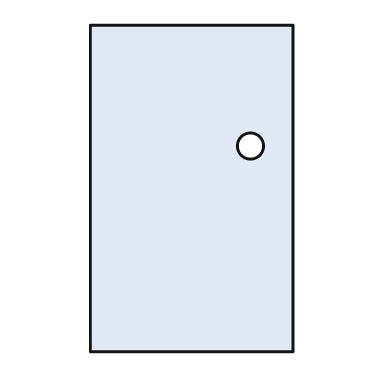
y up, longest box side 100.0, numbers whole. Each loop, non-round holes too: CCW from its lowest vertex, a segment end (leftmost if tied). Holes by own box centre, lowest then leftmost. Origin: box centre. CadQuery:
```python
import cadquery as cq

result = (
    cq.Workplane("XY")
    .moveTo(-31.0, -50.0)
    .lineTo(31.0, -50.0)
    .lineTo(31.0, 50.0)
    .lineTo(-31.0, 50.0)
    .close()
    .moveTo(18.0, 13.0)
    .circle(4.0)
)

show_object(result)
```